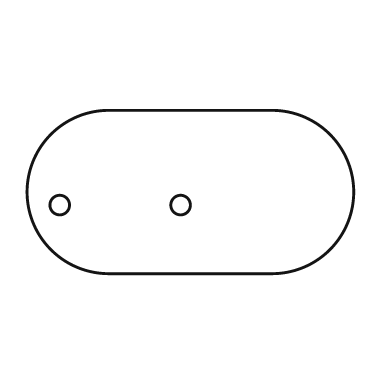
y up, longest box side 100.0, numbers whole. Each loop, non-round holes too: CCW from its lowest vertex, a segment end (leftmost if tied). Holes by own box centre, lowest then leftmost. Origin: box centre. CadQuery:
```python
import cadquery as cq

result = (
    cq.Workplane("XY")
    .moveTo(-25.0, -25.0)
    .lineTo(25.0, -25.0)
    .threePointArc((50.0, 0.0), (25.0, 25.0))
    .lineTo(-25.0, 25.0)
    .threePointArc((-50.0, 0.0), (-25.0, -25.0))
    .close()
    .moveTo(-40.0, -4.0)
    .circle(3.0)
    .moveTo(-3.0, -4.0)
    .circle(3.0)
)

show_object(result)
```